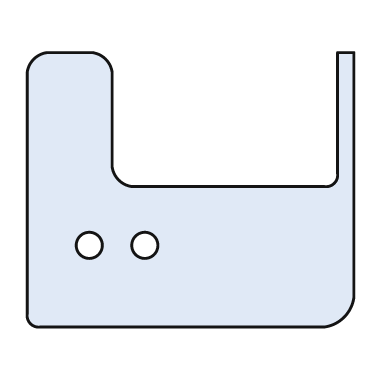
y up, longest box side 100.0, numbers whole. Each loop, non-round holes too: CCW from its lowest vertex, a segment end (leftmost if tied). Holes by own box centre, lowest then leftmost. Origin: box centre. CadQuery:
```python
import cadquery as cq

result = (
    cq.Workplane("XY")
    .moveTo(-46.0, -42.0)
    .lineTo(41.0, -42.0)
    .threePointArc((47.0, -39.0), (50.0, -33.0))
    .lineTo(50.0, 42.0)
    .lineTo(45.0, 42.0)
    .lineTo(45.0, 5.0)
    .threePointArc((44.0, 2.0), (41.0, 1.0))
    .lineTo(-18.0, 1.0)
    .threePointArc((-22.0, 3.0), (-24.0, 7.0))
    .lineTo(-24.0, 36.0)
    .threePointArc((-26.0, 40.0), (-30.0, 42.0))
    .lineTo(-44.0, 42.0)
    .threePointArc((-48.0, 40.0), (-50.0, 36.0))
    .lineTo(-50.0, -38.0)
    .threePointArc((-49.0, -41.0), (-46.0, -42.0))
    .close()
    .moveTo(-31.0, -17.0)
    .circle(4.0)
    .moveTo(-14.0, -17.0)
    .circle(4.0)
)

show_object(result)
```